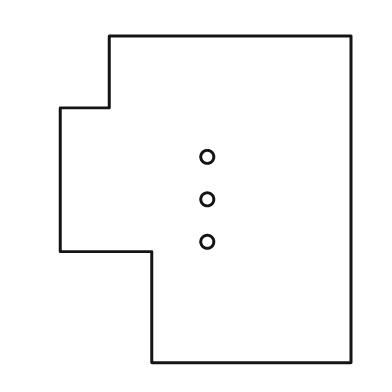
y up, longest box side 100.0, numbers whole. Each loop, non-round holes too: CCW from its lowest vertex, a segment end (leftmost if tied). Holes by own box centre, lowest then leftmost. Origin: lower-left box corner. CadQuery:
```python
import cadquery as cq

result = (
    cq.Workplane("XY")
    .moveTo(28.0, 0.0)
    .lineTo(89.0, 0.0)
    .lineTo(89.0, 100.0)
    .lineTo(15.0, 100.0)
    .lineTo(15.0, 78.0)
    .lineTo(0.0, 78.0)
    .lineTo(0.0, 34.0)
    .lineTo(28.0, 34.0)
    .close()
    .moveTo(45.0, 37.0)
    .circle(2.0)
    .moveTo(45.0, 50.0)
    .circle(2.0)
    .moveTo(45.0, 63.0)
    .circle(2.0)
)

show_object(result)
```